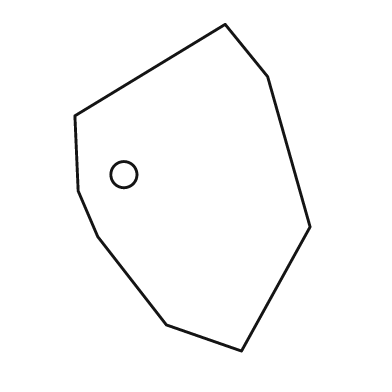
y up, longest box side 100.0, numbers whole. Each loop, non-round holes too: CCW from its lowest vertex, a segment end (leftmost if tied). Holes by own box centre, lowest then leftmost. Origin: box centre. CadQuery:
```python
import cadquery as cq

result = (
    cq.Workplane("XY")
    .moveTo(15.0, -50.0)
    .lineTo(36.0, -12.0)
    .lineTo(23.0, 34.0)
    .lineTo(10.0, 50.0)
    .lineTo(-36.0, 22.0)
    .lineTo(-35.0, -1.0)
    .lineTo(-29.0, -15.0)
    .lineTo(-8.0, -42.0)
    .close()
    .moveTo(-21.0, 4.0)
    .circle(4.0)
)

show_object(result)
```